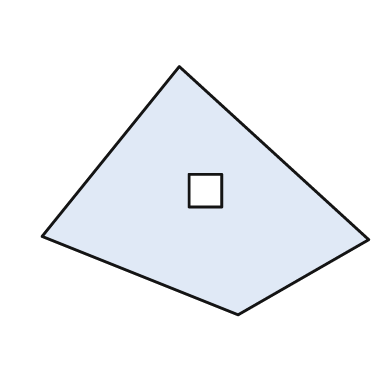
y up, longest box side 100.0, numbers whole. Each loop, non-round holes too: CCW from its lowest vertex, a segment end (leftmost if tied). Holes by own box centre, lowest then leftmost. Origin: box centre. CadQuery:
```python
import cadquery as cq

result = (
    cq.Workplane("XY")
    .moveTo(10.0, -38.0)
    .lineTo(50.0, -15.0)
    .lineTo(-8.0, 38.0)
    .lineTo(-50.0, -14.0)
    .close()
    .moveTo(-5.0, -5.0)
    .lineTo(5.0, -5.0)
    .lineTo(5.0, 5.0)
    .lineTo(-5.0, 5.0)
    .close()
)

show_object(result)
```